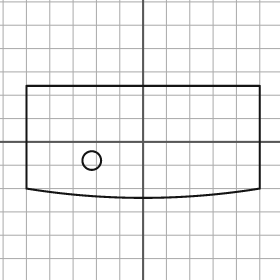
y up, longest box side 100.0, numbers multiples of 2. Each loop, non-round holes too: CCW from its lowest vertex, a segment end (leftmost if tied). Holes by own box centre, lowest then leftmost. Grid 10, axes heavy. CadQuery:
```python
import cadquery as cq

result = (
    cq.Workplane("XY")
    .moveTo(-50.0, -20.0)
    .threePointArc((0.0, -24.0), (50.0, -20.0))
    .lineTo(50.0, 24.0)
    .lineTo(-50.0, 24.0)
    .close()
    .moveTo(-22.0, -8.0)
    .circle(4.0)
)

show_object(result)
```